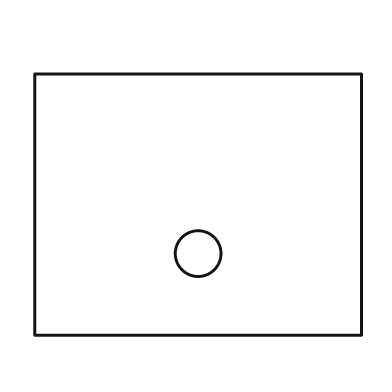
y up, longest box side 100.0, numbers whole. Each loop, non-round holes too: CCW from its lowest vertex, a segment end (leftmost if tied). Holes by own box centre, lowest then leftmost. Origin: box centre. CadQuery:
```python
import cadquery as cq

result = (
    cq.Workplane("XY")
    .moveTo(-50.0, -40.0)
    .lineTo(50.0, -40.0)
    .lineTo(50.0, 40.0)
    .lineTo(-50.0, 40.0)
    .close()
    .moveTo(0.0, -15.0)
    .circle(7.0)
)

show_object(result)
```